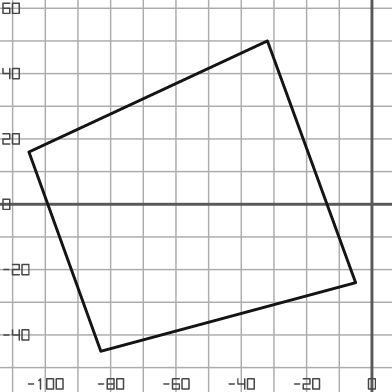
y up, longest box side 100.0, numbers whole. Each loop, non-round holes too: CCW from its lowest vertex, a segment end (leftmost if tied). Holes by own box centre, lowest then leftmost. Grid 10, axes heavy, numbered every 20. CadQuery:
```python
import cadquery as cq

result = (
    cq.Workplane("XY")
    .moveTo(-83.0, -45.0)
    .lineTo(-5.0, -24.0)
    .lineTo(-32.0, 50.0)
    .lineTo(-105.0, 16.0)
    .close()
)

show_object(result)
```